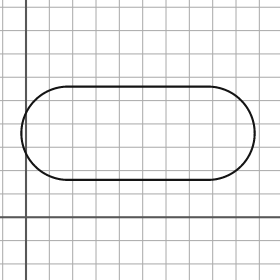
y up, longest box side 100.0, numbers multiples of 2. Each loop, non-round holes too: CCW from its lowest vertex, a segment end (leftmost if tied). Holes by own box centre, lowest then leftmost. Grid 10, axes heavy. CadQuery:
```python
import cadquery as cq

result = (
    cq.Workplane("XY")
    .moveTo(18.0, 16.0)
    .lineTo(78.0, 16.0)
    .threePointArc((98.0, 36.0), (78.0, 56.0))
    .lineTo(18.0, 56.0)
    .threePointArc((-2.0, 36.0), (18.0, 16.0))
    .close()
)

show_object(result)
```